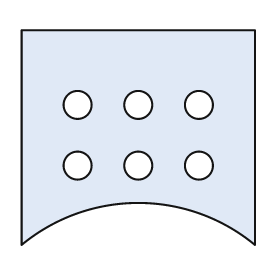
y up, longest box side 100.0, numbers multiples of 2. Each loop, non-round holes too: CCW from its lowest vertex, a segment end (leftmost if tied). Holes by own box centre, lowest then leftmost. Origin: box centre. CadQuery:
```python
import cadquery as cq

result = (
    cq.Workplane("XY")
    .moveTo(-50.0, -46.0)
    .threePointArc((0.0, -28.0), (50.0, -46.0))
    .lineTo(50.0, 46.0)
    .lineTo(-50.0, 46.0)
    .close()
    .moveTo(-26.0, -12.0)
    .circle(6.0)
    .moveTo(0.0, -12.0)
    .circle(6.0)
    .moveTo(26.0, -12.0)
    .circle(6.0)
    .moveTo(-26.0, 14.0)
    .circle(6.0)
    .moveTo(0.0, 14.0)
    .circle(6.0)
    .moveTo(26.0, 14.0)
    .circle(6.0)
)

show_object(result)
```